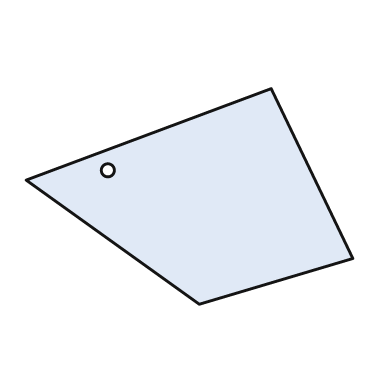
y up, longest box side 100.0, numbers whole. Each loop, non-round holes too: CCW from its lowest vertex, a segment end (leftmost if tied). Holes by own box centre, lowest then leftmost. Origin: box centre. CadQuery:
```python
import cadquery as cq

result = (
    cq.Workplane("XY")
    .moveTo(3.0, -33.0)
    .lineTo(50.0, -19.0)
    .lineTo(25.0, 33.0)
    .lineTo(-50.0, 5.0)
    .close()
    .moveTo(-25.0, 8.0)
    .circle(2.0)
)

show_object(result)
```